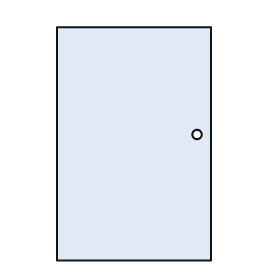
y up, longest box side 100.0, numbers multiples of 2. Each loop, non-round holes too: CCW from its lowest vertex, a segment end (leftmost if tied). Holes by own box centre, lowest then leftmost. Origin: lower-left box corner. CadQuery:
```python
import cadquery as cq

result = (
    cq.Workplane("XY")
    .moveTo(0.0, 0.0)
    .lineTo(66.0, 0.0)
    .lineTo(66.0, 100.0)
    .lineTo(0.0, 100.0)
    .close()
    .moveTo(60.0, 54.0)
    .circle(2.0)
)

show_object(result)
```